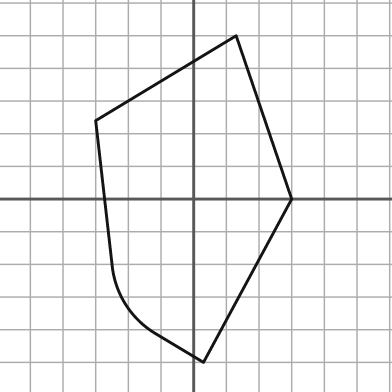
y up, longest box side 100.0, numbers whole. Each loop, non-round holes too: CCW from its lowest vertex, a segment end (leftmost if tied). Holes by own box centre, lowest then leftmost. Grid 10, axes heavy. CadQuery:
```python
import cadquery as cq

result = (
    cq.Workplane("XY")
    .moveTo(3.0, -50.0)
    .lineTo(30.0, 0.0)
    .lineTo(13.0, 50.0)
    .lineTo(-30.0, 24.0)
    .lineTo(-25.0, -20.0)
    .threePointArc((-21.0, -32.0), (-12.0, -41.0))
    .close()
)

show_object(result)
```